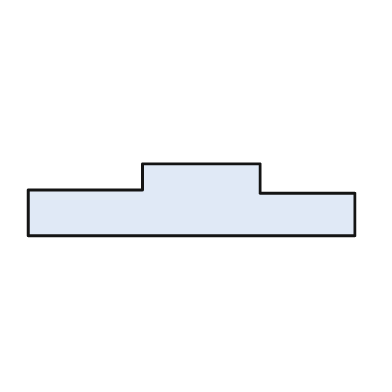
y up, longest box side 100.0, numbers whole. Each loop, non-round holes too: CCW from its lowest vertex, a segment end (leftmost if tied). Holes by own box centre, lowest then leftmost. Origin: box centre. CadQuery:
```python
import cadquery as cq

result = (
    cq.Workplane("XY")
    .moveTo(-50.0, -11.0)
    .lineTo(50.0, -11.0)
    .lineTo(50.0, 2.0)
    .lineTo(21.0, 2.0)
    .lineTo(21.0, 11.0)
    .lineTo(-15.0, 11.0)
    .lineTo(-15.0, 3.0)
    .lineTo(-50.0, 3.0)
    .close()
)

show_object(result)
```